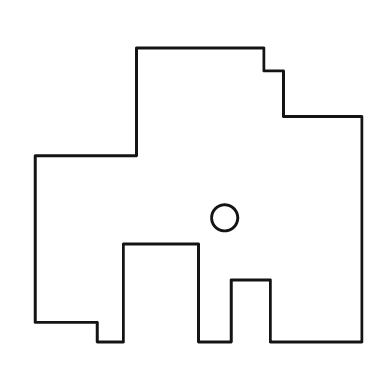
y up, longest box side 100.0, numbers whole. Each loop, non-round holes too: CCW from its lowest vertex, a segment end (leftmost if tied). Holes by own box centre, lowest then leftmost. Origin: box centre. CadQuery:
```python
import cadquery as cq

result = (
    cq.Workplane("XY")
    .moveTo(-31.0, -45.0)
    .lineTo(-23.0, -45.0)
    .lineTo(-23.0, -15.0)
    .lineTo(0.0, -15.0)
    .lineTo(0.0, -45.0)
    .lineTo(10.0, -45.0)
    .lineTo(10.0, -26.0)
    .lineTo(22.0, -26.0)
    .lineTo(22.0, -45.0)
    .lineTo(50.0, -45.0)
    .lineTo(50.0, 24.0)
    .lineTo(26.0, 24.0)
    .lineTo(26.0, 38.0)
    .lineTo(20.0, 38.0)
    .lineTo(20.0, 45.0)
    .lineTo(-19.0, 45.0)
    .lineTo(-19.0, 12.0)
    .lineTo(-50.0, 12.0)
    .lineTo(-50.0, -39.0)
    .lineTo(-31.0, -39.0)
    .close()
    .moveTo(8.0, -7.0)
    .circle(4.0)
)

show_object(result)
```